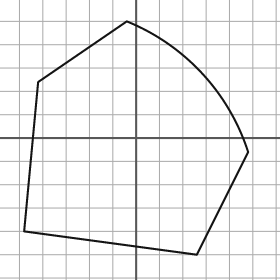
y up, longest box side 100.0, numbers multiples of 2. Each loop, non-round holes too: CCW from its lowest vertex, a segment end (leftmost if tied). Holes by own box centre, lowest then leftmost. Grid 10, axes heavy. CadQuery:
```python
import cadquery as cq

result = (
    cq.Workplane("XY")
    .moveTo(26.0, -50.0)
    .lineTo(48.0, -6.0)
    .threePointArc((28.0, 28.0), (-4.0, 50.0))
    .lineTo(-42.0, 24.0)
    .lineTo(-48.0, -40.0)
    .close()
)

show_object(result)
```